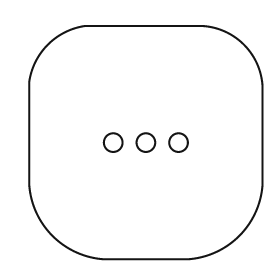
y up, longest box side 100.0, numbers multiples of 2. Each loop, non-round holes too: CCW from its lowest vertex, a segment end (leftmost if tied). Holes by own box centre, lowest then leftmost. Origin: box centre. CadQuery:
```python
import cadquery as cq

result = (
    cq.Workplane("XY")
    .moveTo(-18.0, -50.0)
    .lineTo(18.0, -50.0)
    .threePointArc((40.0, -40.0), (50.0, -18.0))
    .lineTo(50.0, 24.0)
    .threePointArc((42.0, 42.0), (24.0, 50.0))
    .lineTo(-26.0, 50.0)
    .threePointArc((-42.0, 42.0), (-50.0, 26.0))
    .lineTo(-50.0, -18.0)
    .threePointArc((-40.0, -40.0), (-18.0, -50.0))
    .close()
    .moveTo(-14.0, 0.0)
    .circle(4.0)
    .moveTo(0.0, 0.0)
    .circle(4.0)
    .moveTo(14.0, 0.0)
    .circle(4.0)
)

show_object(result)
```